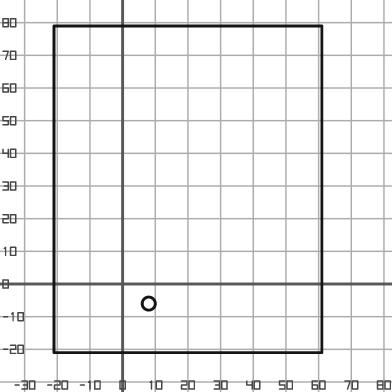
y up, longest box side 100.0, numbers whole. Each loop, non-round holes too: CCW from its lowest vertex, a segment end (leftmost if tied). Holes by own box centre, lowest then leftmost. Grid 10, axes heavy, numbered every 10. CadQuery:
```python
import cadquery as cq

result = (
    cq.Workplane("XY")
    .moveTo(-21.0, -21.0)
    .lineTo(61.0, -21.0)
    .lineTo(61.0, 79.0)
    .lineTo(-21.0, 79.0)
    .close()
    .moveTo(8.0, -6.0)
    .circle(2.0)
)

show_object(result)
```